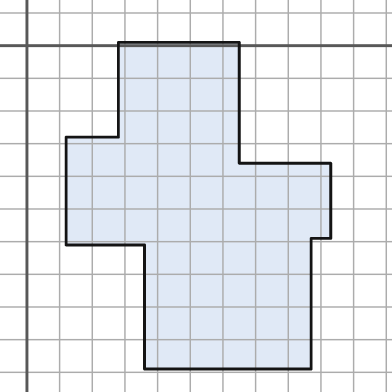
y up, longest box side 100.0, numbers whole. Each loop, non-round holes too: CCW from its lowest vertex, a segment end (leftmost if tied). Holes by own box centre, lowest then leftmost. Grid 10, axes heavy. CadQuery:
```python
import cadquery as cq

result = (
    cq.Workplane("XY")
    .moveTo(36.0, -99.0)
    .lineTo(87.0, -99.0)
    .lineTo(87.0, -59.0)
    .lineTo(93.0, -59.0)
    .lineTo(93.0, -36.0)
    .lineTo(65.0, -36.0)
    .lineTo(65.0, 1.0)
    .lineTo(28.0, 1.0)
    .lineTo(28.0, -28.0)
    .lineTo(12.0, -28.0)
    .lineTo(12.0, -61.0)
    .lineTo(36.0, -61.0)
    .close()
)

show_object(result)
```